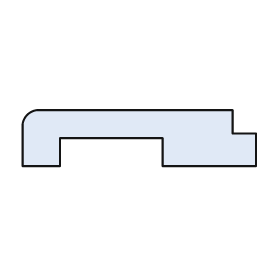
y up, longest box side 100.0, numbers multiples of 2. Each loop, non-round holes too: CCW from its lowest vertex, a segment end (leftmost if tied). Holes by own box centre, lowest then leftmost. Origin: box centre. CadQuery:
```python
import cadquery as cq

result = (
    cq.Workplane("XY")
    .moveTo(-50.0, -12.0)
    .lineTo(-34.0, -12.0)
    .lineTo(-34.0, 0.0)
    .lineTo(10.0, 0.0)
    .lineTo(10.0, -12.0)
    .lineTo(50.0, -12.0)
    .lineTo(50.0, 2.0)
    .lineTo(40.0, 2.0)
    .lineTo(40.0, 12.0)
    .lineTo(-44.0, 12.0)
    .threePointArc((-48.0, 10.0), (-50.0, 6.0))
    .close()
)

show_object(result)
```